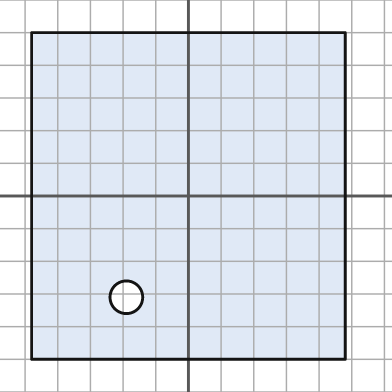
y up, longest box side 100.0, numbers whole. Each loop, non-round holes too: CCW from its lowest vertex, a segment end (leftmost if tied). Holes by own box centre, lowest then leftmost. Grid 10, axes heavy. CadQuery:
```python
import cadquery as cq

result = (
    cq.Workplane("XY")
    .moveTo(-48.0, -50.0)
    .lineTo(48.0, -50.0)
    .lineTo(48.0, 50.0)
    .lineTo(-48.0, 50.0)
    .close()
    .moveTo(-19.0, -31.0)
    .circle(5.0)
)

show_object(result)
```